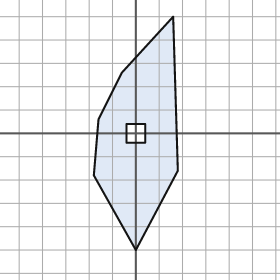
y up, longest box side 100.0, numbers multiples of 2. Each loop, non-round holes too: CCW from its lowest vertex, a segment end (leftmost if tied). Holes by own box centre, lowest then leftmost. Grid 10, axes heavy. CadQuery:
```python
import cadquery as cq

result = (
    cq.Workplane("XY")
    .moveTo(0.0, -50.0)
    .lineTo(18.0, -16.0)
    .lineTo(16.0, 50.0)
    .lineTo(-6.0, 26.0)
    .lineTo(-16.0, 6.0)
    .lineTo(-18.0, -18.0)
    .close()
    .moveTo(-4.0, -4.0)
    .lineTo(4.0, -4.0)
    .lineTo(4.0, 4.0)
    .lineTo(-4.0, 4.0)
    .close()
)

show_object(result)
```